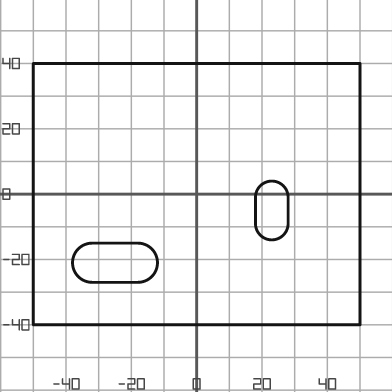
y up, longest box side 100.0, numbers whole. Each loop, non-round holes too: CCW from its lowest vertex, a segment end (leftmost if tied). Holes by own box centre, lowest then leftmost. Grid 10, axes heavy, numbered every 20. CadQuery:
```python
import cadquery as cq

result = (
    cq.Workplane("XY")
    .moveTo(-50.0, -40.0)
    .lineTo(50.0, -40.0)
    .lineTo(50.0, 40.0)
    .lineTo(-50.0, 40.0)
    .close()
    .moveTo(-32.0, -27.0)
    .lineTo(-18.0, -27.0)
    .threePointArc((-12.0, -21.0), (-18.0, -15.0))
    .lineTo(-32.0, -15.0)
    .threePointArc((-38.0, -21.0), (-32.0, -27.0))
    .close()
    .moveTo(18.0, -9.0)
    .threePointArc((23.0, -14.0), (28.0, -9.0))
    .lineTo(28.0, -1.0)
    .threePointArc((23.0, 4.0), (18.0, -1.0))
    .close()
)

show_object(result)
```